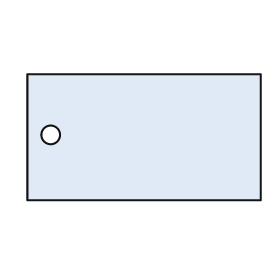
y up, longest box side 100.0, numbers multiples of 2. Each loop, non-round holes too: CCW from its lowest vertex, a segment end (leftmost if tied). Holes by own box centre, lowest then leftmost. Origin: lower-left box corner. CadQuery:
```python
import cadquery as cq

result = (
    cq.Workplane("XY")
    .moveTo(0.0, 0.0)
    .lineTo(100.0, 0.0)
    .lineTo(100.0, 54.0)
    .lineTo(0.0, 54.0)
    .close()
    .moveTo(10.0, 28.0)
    .circle(4.0)
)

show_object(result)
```